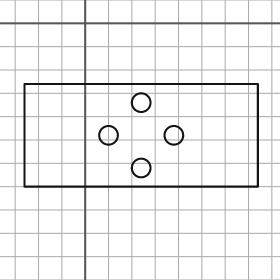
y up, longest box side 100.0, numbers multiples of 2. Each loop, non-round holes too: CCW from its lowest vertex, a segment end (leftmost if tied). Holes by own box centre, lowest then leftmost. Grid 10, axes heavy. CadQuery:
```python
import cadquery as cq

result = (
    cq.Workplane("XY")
    .moveTo(-26.0, -70.0)
    .lineTo(74.0, -70.0)
    .lineTo(74.0, -26.0)
    .lineTo(-26.0, -26.0)
    .close()
    .moveTo(24.0, -62.0)
    .circle(4.0)
    .moveTo(10.0, -48.0)
    .circle(4.0)
    .moveTo(38.0, -48.0)
    .circle(4.0)
    .moveTo(24.0, -34.0)
    .circle(4.0)
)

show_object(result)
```